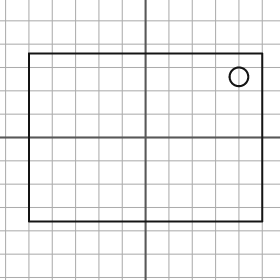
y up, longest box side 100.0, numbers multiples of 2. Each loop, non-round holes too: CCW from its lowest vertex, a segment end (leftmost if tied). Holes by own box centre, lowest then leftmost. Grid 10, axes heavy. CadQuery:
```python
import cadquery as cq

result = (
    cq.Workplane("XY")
    .moveTo(-50.0, -36.0)
    .lineTo(50.0, -36.0)
    .lineTo(50.0, 36.0)
    .lineTo(-50.0, 36.0)
    .close()
    .moveTo(40.0, 26.0)
    .circle(4.0)
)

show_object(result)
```